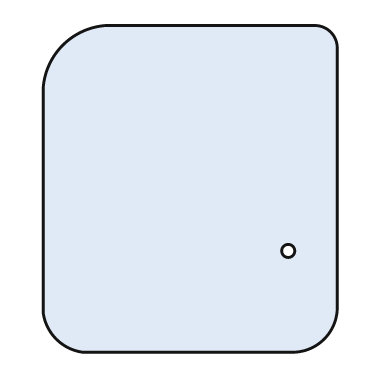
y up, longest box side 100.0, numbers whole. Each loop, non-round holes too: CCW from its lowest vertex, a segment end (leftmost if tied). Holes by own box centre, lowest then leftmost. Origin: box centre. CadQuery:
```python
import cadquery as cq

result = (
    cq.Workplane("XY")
    .moveTo(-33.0, -50.0)
    .lineTo(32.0, -50.0)
    .threePointArc((41.0, -46.0), (45.0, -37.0))
    .lineTo(45.0, 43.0)
    .threePointArc((43.0, 48.0), (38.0, 50.0))
    .lineTo(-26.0, 50.0)
    .threePointArc((-39.0, 44.0), (-45.0, 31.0))
    .lineTo(-45.0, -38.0)
    .threePointArc((-41.0, -46.0), (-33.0, -50.0))
    .close()
    .moveTo(30.0, -19.0)
    .circle(2.0)
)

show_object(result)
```